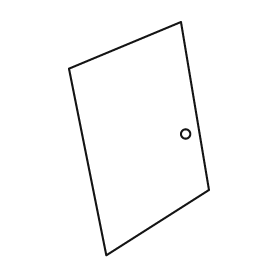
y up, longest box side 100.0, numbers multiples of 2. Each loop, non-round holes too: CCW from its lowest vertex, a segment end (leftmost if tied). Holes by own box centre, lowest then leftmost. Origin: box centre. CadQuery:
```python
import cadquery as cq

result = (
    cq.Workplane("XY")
    .moveTo(-14.0, -50.0)
    .lineTo(30.0, -22.0)
    .lineTo(18.0, 50.0)
    .lineTo(-30.0, 30.0)
    .close()
    .moveTo(20.0, 2.0)
    .circle(2.0)
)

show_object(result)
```